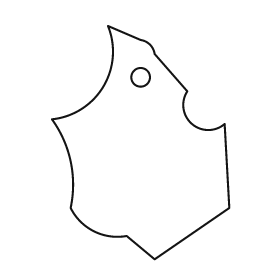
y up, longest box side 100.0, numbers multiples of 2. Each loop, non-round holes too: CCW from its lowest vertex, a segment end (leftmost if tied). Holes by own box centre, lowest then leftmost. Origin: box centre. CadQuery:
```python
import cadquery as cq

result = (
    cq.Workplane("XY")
    .moveTo(6.0, -50.0)
    .lineTo(38.0, -28.0)
    .lineTo(36.0, 8.0)
    .threePointArc((22.0, 8.0), (20.0, 22.0))
    .lineTo(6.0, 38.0)
    .threePointArc((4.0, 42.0), (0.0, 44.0))
    .lineTo(-14.0, 50.0)
    .threePointArc((-16.0, 24.0), (-38.0, 10.0))
    .threePointArc((-30.0, -8.0), (-30.0, -28.0))
    .threePointArc((-20.0, -38.0), (-6.0, -40.0))
    .close()
    .moveTo(0.0, 28.0)
    .circle(4.0)
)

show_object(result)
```